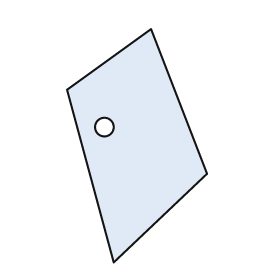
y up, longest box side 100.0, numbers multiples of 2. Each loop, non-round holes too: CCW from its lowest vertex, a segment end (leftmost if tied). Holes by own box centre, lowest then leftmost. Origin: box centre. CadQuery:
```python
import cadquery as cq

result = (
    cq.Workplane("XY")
    .moveTo(-10.0, -50.0)
    .lineTo(30.0, -12.0)
    .lineTo(6.0, 50.0)
    .lineTo(-30.0, 24.0)
    .close()
    .moveTo(-14.0, 8.0)
    .circle(4.0)
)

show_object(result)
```